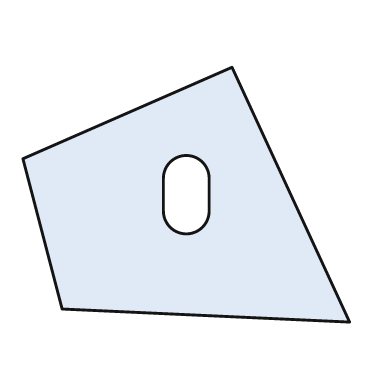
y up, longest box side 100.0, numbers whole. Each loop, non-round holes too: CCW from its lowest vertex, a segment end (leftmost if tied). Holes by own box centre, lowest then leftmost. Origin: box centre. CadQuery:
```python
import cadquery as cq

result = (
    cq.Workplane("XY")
    .moveTo(50.0, -39.0)
    .lineTo(14.0, 39.0)
    .lineTo(-50.0, 11.0)
    .lineTo(-38.0, -35.0)
    .close()
    .moveTo(-7.0, -5.0)
    .threePointArc((0.0, -12.0), (7.0, -5.0))
    .lineTo(7.0, 5.0)
    .threePointArc((0.0, 12.0), (-7.0, 5.0))
    .close()
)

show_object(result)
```